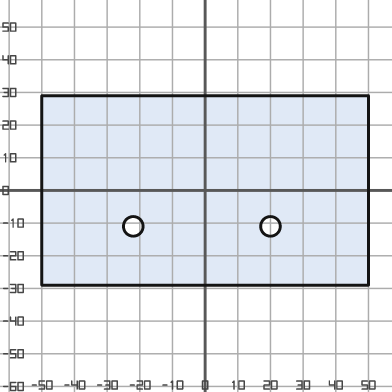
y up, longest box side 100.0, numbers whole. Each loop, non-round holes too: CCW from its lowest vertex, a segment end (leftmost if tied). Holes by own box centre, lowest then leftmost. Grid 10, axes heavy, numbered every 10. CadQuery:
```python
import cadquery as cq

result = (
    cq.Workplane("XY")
    .moveTo(-50.0, -29.0)
    .lineTo(50.0, -29.0)
    .lineTo(50.0, 29.0)
    .lineTo(-50.0, 29.0)
    .close()
    .moveTo(-22.0, -11.0)
    .circle(3.0)
    .moveTo(20.0, -11.0)
    .circle(3.0)
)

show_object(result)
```